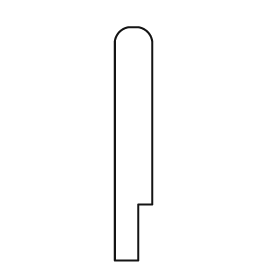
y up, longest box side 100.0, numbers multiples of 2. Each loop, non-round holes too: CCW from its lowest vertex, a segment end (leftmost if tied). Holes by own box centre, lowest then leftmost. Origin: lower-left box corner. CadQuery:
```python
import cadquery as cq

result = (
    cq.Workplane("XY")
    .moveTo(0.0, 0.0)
    .lineTo(10.0, 0.0)
    .lineTo(10.0, 24.0)
    .lineTo(16.0, 24.0)
    .lineTo(16.0, 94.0)
    .threePointArc((14.0, 98.0), (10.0, 100.0))
    .lineTo(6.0, 100.0)
    .threePointArc((2.0, 98.0), (0.0, 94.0))
    .close()
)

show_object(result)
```